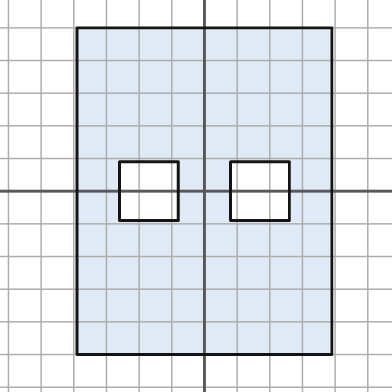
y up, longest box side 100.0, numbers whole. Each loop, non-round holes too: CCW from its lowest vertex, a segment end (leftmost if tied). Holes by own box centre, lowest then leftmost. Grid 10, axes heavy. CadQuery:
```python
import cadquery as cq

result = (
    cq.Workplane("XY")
    .moveTo(-39.0, -50.0)
    .lineTo(39.0, -50.0)
    .lineTo(39.0, 50.0)
    .lineTo(-39.0, 50.0)
    .close()
    .moveTo(-26.0, -9.0)
    .lineTo(-8.0, -9.0)
    .lineTo(-8.0, 9.0)
    .lineTo(-26.0, 9.0)
    .close()
    .moveTo(8.0, -9.0)
    .lineTo(26.0, -9.0)
    .lineTo(26.0, 9.0)
    .lineTo(8.0, 9.0)
    .close()
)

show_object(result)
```